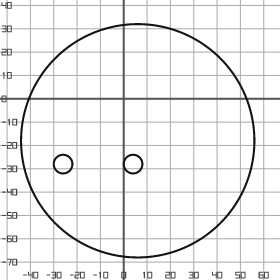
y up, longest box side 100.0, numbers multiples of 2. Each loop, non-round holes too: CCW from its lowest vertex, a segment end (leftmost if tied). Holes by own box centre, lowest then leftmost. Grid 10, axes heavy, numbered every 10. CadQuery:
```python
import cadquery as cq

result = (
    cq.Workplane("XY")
    .moveTo(6.0, -18.0)
    .circle(50.0)
    .moveTo(-26.0, -28.0)
    .circle(4.0)
    .moveTo(4.0, -28.0)
    .circle(4.0)
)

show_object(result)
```